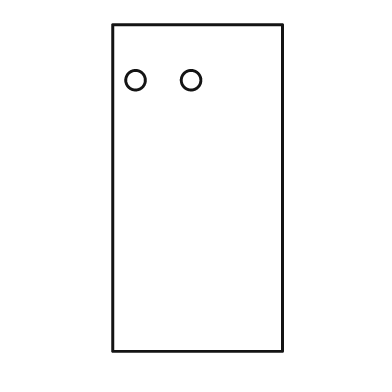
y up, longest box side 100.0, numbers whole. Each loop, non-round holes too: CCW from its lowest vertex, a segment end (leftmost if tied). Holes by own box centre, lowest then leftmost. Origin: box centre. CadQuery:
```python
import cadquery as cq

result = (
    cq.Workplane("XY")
    .moveTo(-26.0, -50.0)
    .lineTo(26.0, -50.0)
    .lineTo(26.0, 50.0)
    .lineTo(-26.0, 50.0)
    .close()
    .moveTo(-19.0, 33.0)
    .circle(3.0)
    .moveTo(-2.0, 33.0)
    .circle(3.0)
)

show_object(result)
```